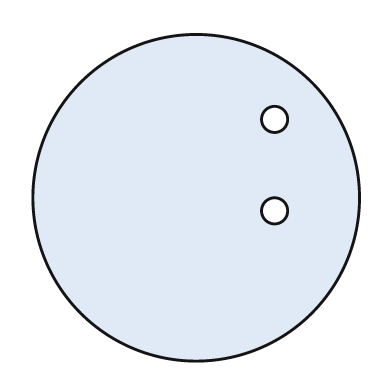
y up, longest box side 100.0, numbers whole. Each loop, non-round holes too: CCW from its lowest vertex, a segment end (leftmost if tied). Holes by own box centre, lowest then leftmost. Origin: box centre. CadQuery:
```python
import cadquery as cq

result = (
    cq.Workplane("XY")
    .moveTo(0.0, 0.0)
    .circle(50.0)
    .moveTo(24.0, -4.0)
    .circle(4.0)
    .moveTo(24.0, 24.0)
    .circle(4.0)
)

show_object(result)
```